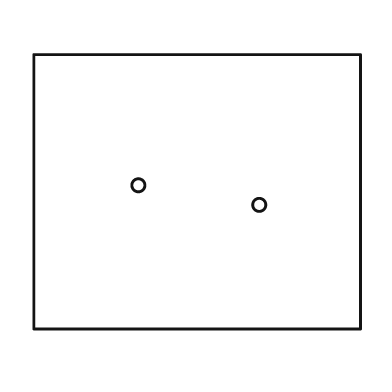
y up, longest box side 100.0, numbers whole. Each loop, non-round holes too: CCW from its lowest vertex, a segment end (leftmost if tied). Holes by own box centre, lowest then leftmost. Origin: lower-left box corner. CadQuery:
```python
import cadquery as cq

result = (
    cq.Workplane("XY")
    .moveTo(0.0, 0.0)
    .lineTo(100.0, 0.0)
    .lineTo(100.0, 84.0)
    .lineTo(0.0, 84.0)
    .close()
    .moveTo(69.0, 38.0)
    .circle(2.0)
    .moveTo(32.0, 44.0)
    .circle(2.0)
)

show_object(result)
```